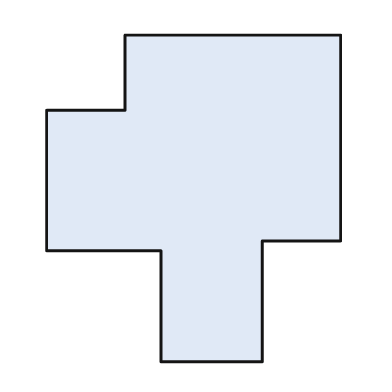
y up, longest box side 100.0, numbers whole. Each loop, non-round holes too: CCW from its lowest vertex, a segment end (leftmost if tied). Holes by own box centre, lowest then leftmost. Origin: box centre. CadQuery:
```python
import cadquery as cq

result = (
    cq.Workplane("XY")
    .moveTo(-10.0, -50.0)
    .lineTo(21.0, -50.0)
    .lineTo(21.0, -13.0)
    .lineTo(45.0, -13.0)
    .lineTo(45.0, 50.0)
    .lineTo(-21.0, 50.0)
    .lineTo(-21.0, 27.0)
    .lineTo(-45.0, 27.0)
    .lineTo(-45.0, -16.0)
    .lineTo(-10.0, -16.0)
    .close()
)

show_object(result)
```